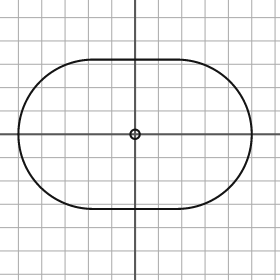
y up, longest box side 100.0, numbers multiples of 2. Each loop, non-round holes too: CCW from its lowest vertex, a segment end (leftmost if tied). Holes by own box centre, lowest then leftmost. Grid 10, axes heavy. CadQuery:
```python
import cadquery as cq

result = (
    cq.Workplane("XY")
    .moveTo(-18.0, -32.0)
    .lineTo(18.0, -32.0)
    .threePointArc((50.0, 0.0), (18.0, 32.0))
    .lineTo(-18.0, 32.0)
    .threePointArc((-50.0, 0.0), (-18.0, -32.0))
    .close()
    .moveTo(0.0, 0.0)
    .circle(2.0)
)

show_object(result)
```